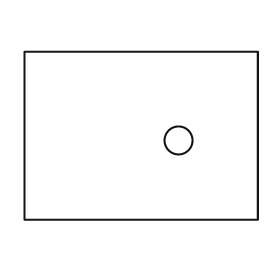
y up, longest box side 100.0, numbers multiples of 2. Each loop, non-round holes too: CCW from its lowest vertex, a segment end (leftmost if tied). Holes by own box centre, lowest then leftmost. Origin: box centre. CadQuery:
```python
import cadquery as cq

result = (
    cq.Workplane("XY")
    .moveTo(-50.0, -36.0)
    .lineTo(50.0, -36.0)
    .lineTo(50.0, 36.0)
    .lineTo(-50.0, 36.0)
    .close()
    .moveTo(16.0, -2.0)
    .circle(6.0)
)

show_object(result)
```